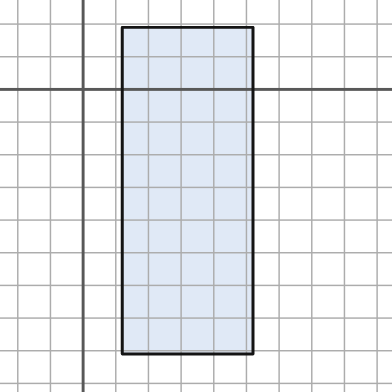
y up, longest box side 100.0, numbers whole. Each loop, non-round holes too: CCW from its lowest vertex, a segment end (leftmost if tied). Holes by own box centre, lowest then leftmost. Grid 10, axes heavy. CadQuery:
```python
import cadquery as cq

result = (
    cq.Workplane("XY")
    .moveTo(12.0, -81.0)
    .lineTo(52.0, -81.0)
    .lineTo(52.0, 19.0)
    .lineTo(12.0, 19.0)
    .close()
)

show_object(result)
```